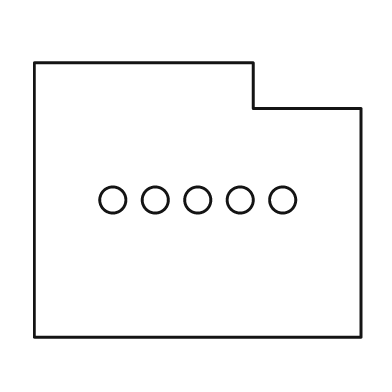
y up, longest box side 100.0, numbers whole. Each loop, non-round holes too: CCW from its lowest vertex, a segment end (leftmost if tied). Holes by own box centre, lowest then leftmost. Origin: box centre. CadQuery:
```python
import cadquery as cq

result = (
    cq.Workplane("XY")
    .moveTo(-50.0, -42.0)
    .lineTo(50.0, -42.0)
    .lineTo(50.0, 28.0)
    .lineTo(17.0, 28.0)
    .lineTo(17.0, 42.0)
    .lineTo(-50.0, 42.0)
    .close()
    .moveTo(-26.0, 0.0)
    .circle(4.0)
    .moveTo(-13.0, 0.0)
    .circle(4.0)
    .moveTo(0.0, 0.0)
    .circle(4.0)
    .moveTo(13.0, 0.0)
    .circle(4.0)
    .moveTo(26.0, 0.0)
    .circle(4.0)
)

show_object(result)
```